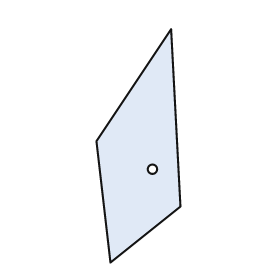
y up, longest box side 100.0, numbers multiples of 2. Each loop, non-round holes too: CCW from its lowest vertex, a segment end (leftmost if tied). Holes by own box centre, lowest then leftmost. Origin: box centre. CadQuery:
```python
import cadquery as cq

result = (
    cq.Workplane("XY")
    .moveTo(-12.0, -50.0)
    .lineTo(18.0, -26.0)
    .lineTo(14.0, 50.0)
    .lineTo(-18.0, 2.0)
    .close()
    .moveTo(6.0, -10.0)
    .circle(2.0)
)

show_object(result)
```